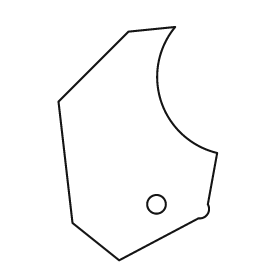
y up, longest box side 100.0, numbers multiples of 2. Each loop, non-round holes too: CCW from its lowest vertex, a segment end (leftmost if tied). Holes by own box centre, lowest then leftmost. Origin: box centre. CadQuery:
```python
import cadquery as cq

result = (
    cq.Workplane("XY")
    .moveTo(-8.0, -50.0)
    .lineTo(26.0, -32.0)
    .threePointArc((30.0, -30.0), (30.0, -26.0))
    .lineTo(34.0, -4.0)
    .threePointArc((10.0, 18.0), (16.0, 50.0))
    .lineTo(-4.0, 48.0)
    .lineTo(-34.0, 18.0)
    .lineTo(-28.0, -34.0)
    .close()
    .moveTo(8.0, -26.0)
    .circle(4.0)
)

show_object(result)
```